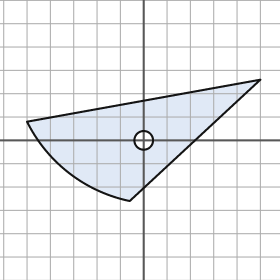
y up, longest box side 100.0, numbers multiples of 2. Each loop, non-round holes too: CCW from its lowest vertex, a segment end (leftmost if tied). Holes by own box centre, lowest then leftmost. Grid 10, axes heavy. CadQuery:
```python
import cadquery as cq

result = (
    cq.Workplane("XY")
    .moveTo(-6.0, -26.0)
    .lineTo(50.0, 26.0)
    .lineTo(-50.0, 8.0)
    .threePointArc((-32.0, -14.0), (-6.0, -26.0))
    .close()
    .moveTo(0.0, 0.0)
    .circle(4.0)
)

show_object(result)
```